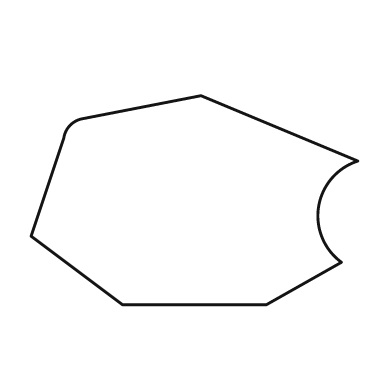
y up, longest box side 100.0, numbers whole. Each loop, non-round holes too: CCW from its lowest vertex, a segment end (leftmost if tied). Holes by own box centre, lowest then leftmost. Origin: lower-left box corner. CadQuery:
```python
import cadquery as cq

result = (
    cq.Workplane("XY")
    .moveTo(28.0, 0.0)
    .lineTo(72.0, 0.0)
    .lineTo(95.0, 13.0)
    .threePointArc((88.0, 30.0), (100.0, 44.0))
    .lineTo(52.0, 64.0)
    .lineTo(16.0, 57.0)
    .threePointArc((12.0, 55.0), (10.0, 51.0))
    .lineTo(0.0, 21.0)
    .close()
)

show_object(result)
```